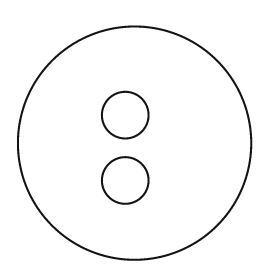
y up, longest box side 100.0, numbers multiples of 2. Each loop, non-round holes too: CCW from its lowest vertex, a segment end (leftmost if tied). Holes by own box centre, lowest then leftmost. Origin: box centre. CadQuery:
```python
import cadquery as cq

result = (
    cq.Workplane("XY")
    .moveTo(0.0, 0.0)
    .circle(50.0)
    .moveTo(-4.0, -16.0)
    .circle(10.0)
    .moveTo(-4.0, 12.0)
    .circle(10.0)
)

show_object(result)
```